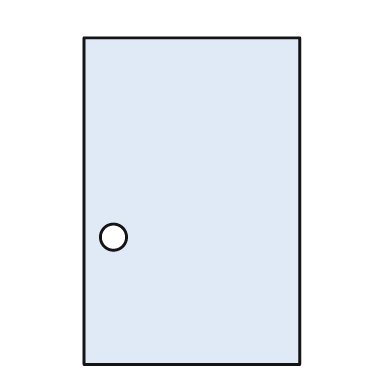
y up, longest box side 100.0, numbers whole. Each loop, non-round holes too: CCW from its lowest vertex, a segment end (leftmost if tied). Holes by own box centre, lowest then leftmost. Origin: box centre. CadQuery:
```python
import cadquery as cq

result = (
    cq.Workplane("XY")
    .moveTo(-33.0, -50.0)
    .lineTo(33.0, -50.0)
    .lineTo(33.0, 50.0)
    .lineTo(-33.0, 50.0)
    .close()
    .moveTo(-24.0, -11.0)
    .circle(4.0)
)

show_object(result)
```